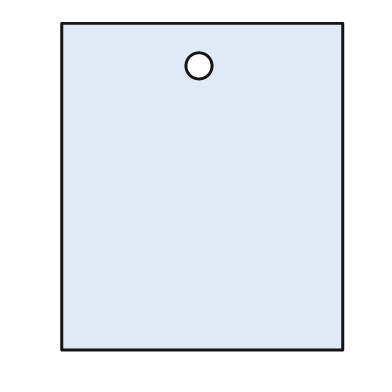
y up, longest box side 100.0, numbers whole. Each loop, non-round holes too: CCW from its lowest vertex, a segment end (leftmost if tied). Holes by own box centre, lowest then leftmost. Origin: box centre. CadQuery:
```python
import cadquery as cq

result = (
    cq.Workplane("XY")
    .moveTo(-43.0, -50.0)
    .lineTo(43.0, -50.0)
    .lineTo(43.0, 50.0)
    .lineTo(-43.0, 50.0)
    .close()
    .moveTo(-1.0, 37.0)
    .circle(4.0)
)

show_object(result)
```